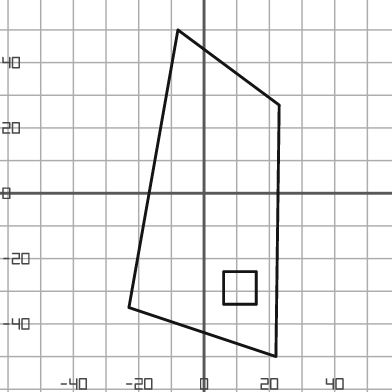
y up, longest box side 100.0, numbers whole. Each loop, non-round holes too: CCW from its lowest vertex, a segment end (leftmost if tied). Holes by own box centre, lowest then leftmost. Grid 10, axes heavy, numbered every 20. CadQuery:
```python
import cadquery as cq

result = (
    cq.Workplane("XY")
    .moveTo(22.0, -50.0)
    .lineTo(23.0, 27.0)
    .lineTo(-8.0, 50.0)
    .lineTo(-23.0, -35.0)
    .close()
    .moveTo(6.0, -34.0)
    .lineTo(16.0, -34.0)
    .lineTo(16.0, -24.0)
    .lineTo(6.0, -24.0)
    .close()
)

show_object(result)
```